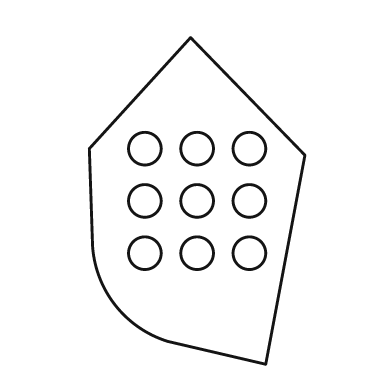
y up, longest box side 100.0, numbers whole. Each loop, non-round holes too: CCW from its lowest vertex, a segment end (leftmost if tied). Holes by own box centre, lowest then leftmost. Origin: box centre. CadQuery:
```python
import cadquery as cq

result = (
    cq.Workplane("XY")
    .moveTo(21.0, -50.0)
    .lineTo(33.0, 14.0)
    .lineTo(-2.0, 50.0)
    .lineTo(-33.0, 16.0)
    .lineTo(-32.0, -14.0)
    .threePointArc((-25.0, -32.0), (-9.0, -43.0))
    .close()
    .moveTo(-16.0, -16.0)
    .circle(5.0)
    .moveTo(0.0, -16.0)
    .circle(5.0)
    .moveTo(16.0, -16.0)
    .circle(5.0)
    .moveTo(-16.0, 0.0)
    .circle(5.0)
    .moveTo(0.0, 0.0)
    .circle(5.0)
    .moveTo(16.0, 0.0)
    .circle(5.0)
    .moveTo(-16.0, 16.0)
    .circle(5.0)
    .moveTo(0.0, 16.0)
    .circle(5.0)
    .moveTo(16.0, 16.0)
    .circle(5.0)
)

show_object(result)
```